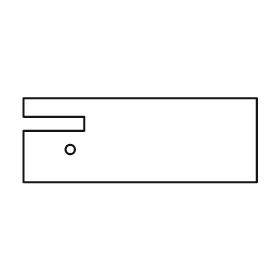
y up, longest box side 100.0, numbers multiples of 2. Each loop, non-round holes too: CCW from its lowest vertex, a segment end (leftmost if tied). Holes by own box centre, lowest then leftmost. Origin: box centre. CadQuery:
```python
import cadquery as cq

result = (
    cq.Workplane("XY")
    .moveTo(-50.0, -18.0)
    .lineTo(50.0, -18.0)
    .lineTo(50.0, 18.0)
    .lineTo(-50.0, 18.0)
    .lineTo(-50.0, 10.0)
    .lineTo(-24.0, 10.0)
    .lineTo(-24.0, 4.0)
    .lineTo(-50.0, 4.0)
    .close()
    .moveTo(-30.0, -4.0)
    .circle(2.0)
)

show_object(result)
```